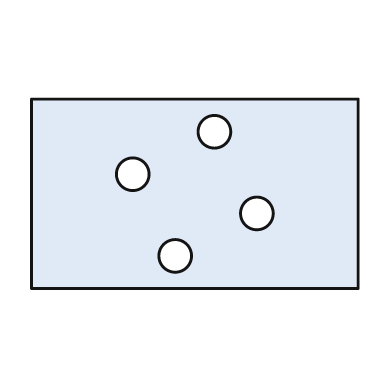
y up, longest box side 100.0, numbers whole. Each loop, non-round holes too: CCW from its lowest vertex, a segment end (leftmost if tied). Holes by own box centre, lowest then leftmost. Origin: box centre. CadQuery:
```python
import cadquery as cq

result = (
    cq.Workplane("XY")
    .moveTo(-50.0, -29.0)
    .lineTo(50.0, -29.0)
    .lineTo(50.0, 29.0)
    .lineTo(-50.0, 29.0)
    .close()
    .moveTo(-6.0, -19.0)
    .circle(5.0)
    .moveTo(19.0, -6.0)
    .circle(5.0)
    .moveTo(-19.0, 6.0)
    .circle(5.0)
    .moveTo(6.0, 19.0)
    .circle(5.0)
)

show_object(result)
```